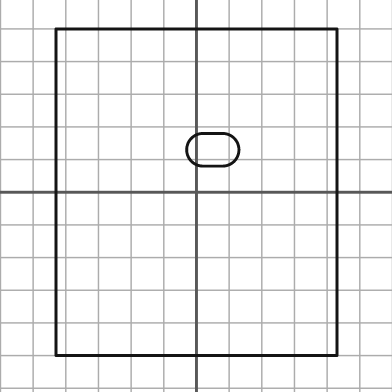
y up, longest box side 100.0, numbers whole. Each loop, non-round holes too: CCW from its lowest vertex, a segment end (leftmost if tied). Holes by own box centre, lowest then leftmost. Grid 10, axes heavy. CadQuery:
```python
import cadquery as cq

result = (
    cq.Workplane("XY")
    .moveTo(-43.0, -50.0)
    .lineTo(43.0, -50.0)
    .lineTo(43.0, 50.0)
    .lineTo(-43.0, 50.0)
    .close()
    .moveTo(2.0, 8.0)
    .lineTo(8.0, 8.0)
    .threePointArc((13.0, 13.0), (8.0, 18.0))
    .lineTo(2.0, 18.0)
    .threePointArc((-3.0, 13.0), (2.0, 8.0))
    .close()
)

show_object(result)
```